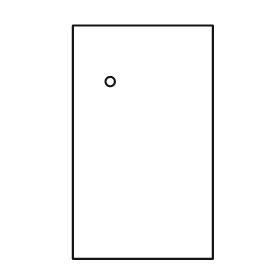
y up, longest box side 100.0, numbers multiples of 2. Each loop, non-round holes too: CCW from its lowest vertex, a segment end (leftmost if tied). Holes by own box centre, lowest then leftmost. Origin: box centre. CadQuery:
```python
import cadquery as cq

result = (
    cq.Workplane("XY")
    .moveTo(-30.0, -50.0)
    .lineTo(30.0, -50.0)
    .lineTo(30.0, 50.0)
    .lineTo(-30.0, 50.0)
    .close()
    .moveTo(-14.0, 26.0)
    .circle(2.0)
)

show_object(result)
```